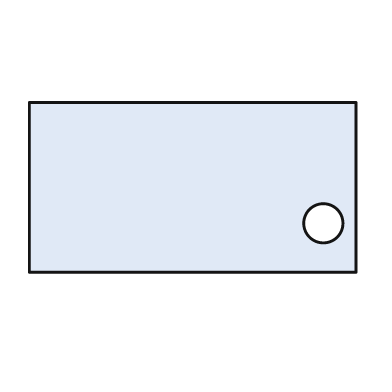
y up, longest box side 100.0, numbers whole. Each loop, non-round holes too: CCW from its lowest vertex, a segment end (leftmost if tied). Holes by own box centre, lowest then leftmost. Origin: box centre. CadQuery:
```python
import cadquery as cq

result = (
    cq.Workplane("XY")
    .moveTo(-50.0, -26.0)
    .lineTo(50.0, -26.0)
    .lineTo(50.0, 26.0)
    .lineTo(-50.0, 26.0)
    .close()
    .moveTo(40.0, -11.0)
    .circle(6.0)
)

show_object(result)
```